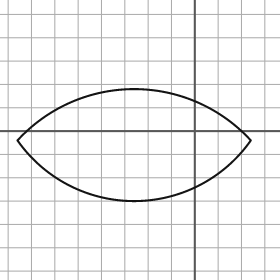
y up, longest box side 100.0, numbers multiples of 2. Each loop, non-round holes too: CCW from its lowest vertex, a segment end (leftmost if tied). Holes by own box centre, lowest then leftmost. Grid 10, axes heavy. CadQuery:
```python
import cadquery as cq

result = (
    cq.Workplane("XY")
    .moveTo(-76.0, -4.0)
    .threePointArc((-26.0, -30.0), (24.0, -4.0))
    .threePointArc((-26.0, 18.0), (-76.0, -4.0))
    .close()
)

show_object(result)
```